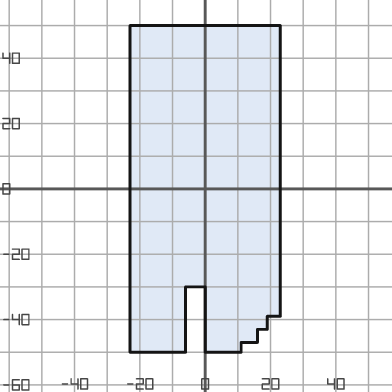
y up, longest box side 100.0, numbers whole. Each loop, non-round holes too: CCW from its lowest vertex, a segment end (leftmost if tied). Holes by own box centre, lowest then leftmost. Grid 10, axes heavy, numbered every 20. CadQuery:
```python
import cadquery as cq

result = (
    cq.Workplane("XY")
    .moveTo(-23.0, -50.0)
    .lineTo(-6.0, -50.0)
    .lineTo(-6.0, -30.0)
    .lineTo(0.0, -30.0)
    .lineTo(0.0, -50.0)
    .lineTo(11.0, -50.0)
    .lineTo(11.0, -47.0)
    .lineTo(16.0, -47.0)
    .lineTo(16.0, -43.0)
    .lineTo(19.0, -43.0)
    .lineTo(19.0, -39.0)
    .lineTo(23.0, -39.0)
    .lineTo(23.0, 50.0)
    .lineTo(-23.0, 50.0)
    .close()
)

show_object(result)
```